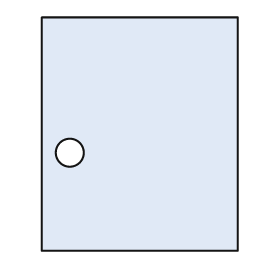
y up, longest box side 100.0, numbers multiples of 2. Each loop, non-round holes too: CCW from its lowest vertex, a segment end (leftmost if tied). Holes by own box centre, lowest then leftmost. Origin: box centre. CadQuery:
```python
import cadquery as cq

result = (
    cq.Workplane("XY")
    .moveTo(-42.0, -50.0)
    .lineTo(42.0, -50.0)
    .lineTo(42.0, 50.0)
    .lineTo(-42.0, 50.0)
    .close()
    .moveTo(-30.0, -8.0)
    .circle(6.0)
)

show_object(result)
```